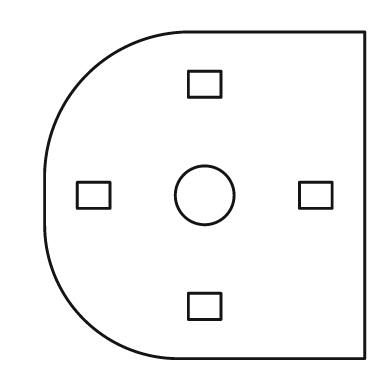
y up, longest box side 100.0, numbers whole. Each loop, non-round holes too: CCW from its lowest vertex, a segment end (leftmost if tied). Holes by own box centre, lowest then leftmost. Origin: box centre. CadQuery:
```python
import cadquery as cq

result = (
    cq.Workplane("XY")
    .moveTo(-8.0, -50.0)
    .lineTo(49.0, -50.0)
    .lineTo(49.0, 50.0)
    .lineTo(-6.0, 50.0)
    .threePointArc((-36.0, 37.0), (-49.0, 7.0))
    .lineTo(-49.0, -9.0)
    .threePointArc((-37.0, -38.0), (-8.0, -50.0))
    .close()
    .moveTo(-5.0, -38.0)
    .lineTo(5.0, -38.0)
    .lineTo(5.0, -30.0)
    .lineTo(-5.0, -30.0)
    .close()
    .moveTo(-39.0, -4.0)
    .lineTo(-29.0, -4.0)
    .lineTo(-29.0, 4.0)
    .lineTo(-39.0, 4.0)
    .close()
    .moveTo(0.0, 0.0)
    .circle(9.0)
    .moveTo(29.0, -4.0)
    .lineTo(39.0, -4.0)
    .lineTo(39.0, 4.0)
    .lineTo(29.0, 4.0)
    .close()
    .moveTo(-5.0, 30.0)
    .lineTo(5.0, 30.0)
    .lineTo(5.0, 38.0)
    .lineTo(-5.0, 38.0)
    .close()
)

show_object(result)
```